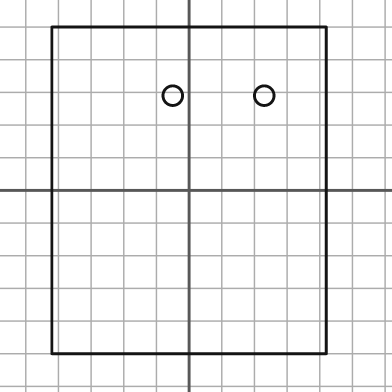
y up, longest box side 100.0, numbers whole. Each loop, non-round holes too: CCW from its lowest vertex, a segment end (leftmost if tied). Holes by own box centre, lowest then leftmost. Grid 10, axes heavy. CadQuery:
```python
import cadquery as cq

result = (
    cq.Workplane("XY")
    .moveTo(-42.0, -50.0)
    .lineTo(42.0, -50.0)
    .lineTo(42.0, 50.0)
    .lineTo(-42.0, 50.0)
    .close()
    .moveTo(-5.0, 29.0)
    .circle(3.0)
    .moveTo(23.0, 29.0)
    .circle(3.0)
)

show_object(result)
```